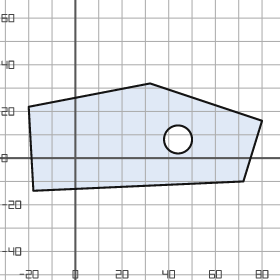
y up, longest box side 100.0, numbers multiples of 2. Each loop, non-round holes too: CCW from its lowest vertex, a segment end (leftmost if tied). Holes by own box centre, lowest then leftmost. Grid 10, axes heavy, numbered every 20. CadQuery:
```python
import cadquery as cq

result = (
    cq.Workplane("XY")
    .moveTo(-18.0, -14.0)
    .lineTo(72.0, -10.0)
    .lineTo(80.0, 16.0)
    .lineTo(32.0, 32.0)
    .lineTo(-20.0, 22.0)
    .close()
    .moveTo(44.0, 8.0)
    .circle(6.0)
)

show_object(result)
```